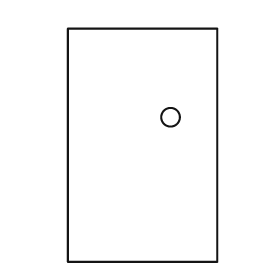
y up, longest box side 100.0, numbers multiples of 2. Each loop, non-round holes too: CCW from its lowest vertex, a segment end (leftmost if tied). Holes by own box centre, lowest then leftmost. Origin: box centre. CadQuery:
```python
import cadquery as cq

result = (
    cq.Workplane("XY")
    .moveTo(-32.0, -50.0)
    .lineTo(32.0, -50.0)
    .lineTo(32.0, 50.0)
    .lineTo(-32.0, 50.0)
    .close()
    .moveTo(12.0, 12.0)
    .circle(4.0)
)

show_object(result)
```